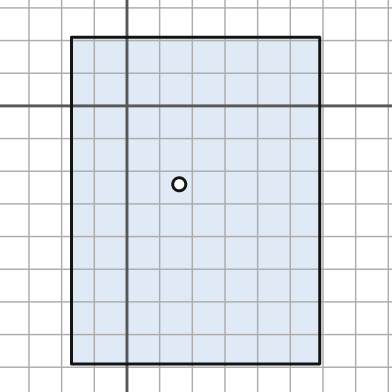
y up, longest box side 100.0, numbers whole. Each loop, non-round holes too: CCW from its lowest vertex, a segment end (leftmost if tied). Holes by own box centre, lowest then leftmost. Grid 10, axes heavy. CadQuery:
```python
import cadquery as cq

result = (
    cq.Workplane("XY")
    .moveTo(-17.0, -79.0)
    .lineTo(59.0, -79.0)
    .lineTo(59.0, 21.0)
    .lineTo(-17.0, 21.0)
    .close()
    .moveTo(16.0, -24.0)
    .circle(2.0)
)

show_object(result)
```